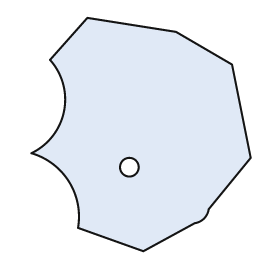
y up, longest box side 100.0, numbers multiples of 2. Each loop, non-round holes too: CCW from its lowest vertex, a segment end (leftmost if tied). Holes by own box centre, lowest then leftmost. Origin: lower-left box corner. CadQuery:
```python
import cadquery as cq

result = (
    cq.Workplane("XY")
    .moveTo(48.0, 0.0)
    .lineTo(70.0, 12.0)
    .threePointArc((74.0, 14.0), (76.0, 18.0))
    .lineTo(94.0, 40.0)
    .lineTo(86.0, 80.0)
    .lineTo(62.0, 94.0)
    .lineTo(24.0, 100.0)
    .lineTo(8.0, 82.0)
    .threePointArc((14.0, 60.0), (0.0, 42.0))
    .threePointArc((16.0, 30.0), (20.0, 10.0))
    .close()
    .moveTo(42.0, 36.0)
    .circle(4.0)
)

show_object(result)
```